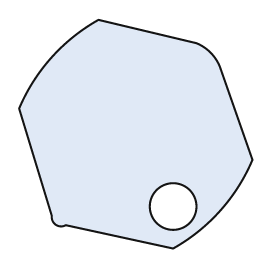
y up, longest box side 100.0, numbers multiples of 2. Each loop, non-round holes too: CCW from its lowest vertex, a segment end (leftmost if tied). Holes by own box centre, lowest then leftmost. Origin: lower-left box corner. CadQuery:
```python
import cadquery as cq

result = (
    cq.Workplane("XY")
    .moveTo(66.0, 0.0)
    .threePointArc((86.0, 16.0), (100.0, 38.0))
    .lineTo(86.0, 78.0)
    .threePointArc((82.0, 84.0), (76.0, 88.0))
    .lineTo(34.0, 98.0)
    .threePointArc((14.0, 82.0), (0.0, 60.0))
    .lineTo(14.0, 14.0)
    .threePointArc((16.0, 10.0), (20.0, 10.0))
    .close()
    .moveTo(66.0, 18.0)
    .circle(10.0)
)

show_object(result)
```